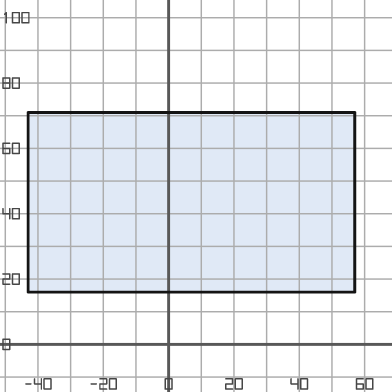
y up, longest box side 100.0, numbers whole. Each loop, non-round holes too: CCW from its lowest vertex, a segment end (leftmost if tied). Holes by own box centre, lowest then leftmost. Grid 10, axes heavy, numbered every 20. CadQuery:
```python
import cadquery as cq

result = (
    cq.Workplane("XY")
    .moveTo(-43.0, 16.0)
    .lineTo(57.0, 16.0)
    .lineTo(57.0, 71.0)
    .lineTo(-43.0, 71.0)
    .close()
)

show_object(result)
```